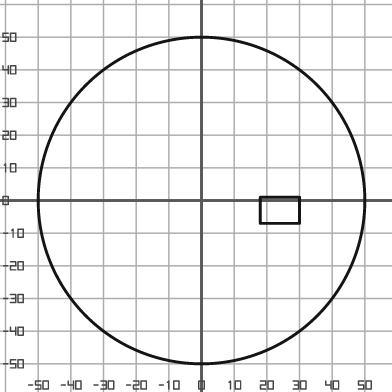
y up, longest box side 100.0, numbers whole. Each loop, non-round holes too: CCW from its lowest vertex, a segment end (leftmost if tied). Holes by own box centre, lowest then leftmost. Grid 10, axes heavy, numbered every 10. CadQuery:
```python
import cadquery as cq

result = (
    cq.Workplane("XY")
    .moveTo(0.0, 0.0)
    .circle(50.0)
    .moveTo(18.0, -7.0)
    .lineTo(30.0, -7.0)
    .lineTo(30.0, 1.0)
    .lineTo(18.0, 1.0)
    .close()
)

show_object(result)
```